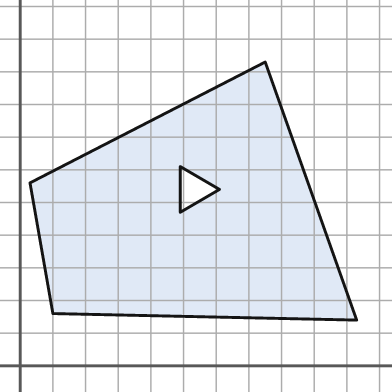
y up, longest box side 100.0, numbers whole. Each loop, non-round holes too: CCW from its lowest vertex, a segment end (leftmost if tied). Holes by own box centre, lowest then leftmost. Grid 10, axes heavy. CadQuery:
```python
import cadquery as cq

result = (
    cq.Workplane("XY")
    .moveTo(103.0, 14.0)
    .lineTo(75.0, 93.0)
    .lineTo(3.0, 56.0)
    .lineTo(10.0, 16.0)
    .close()
    .moveTo(49.0, 47.0)
    .lineTo(61.0, 54.0)
    .lineTo(49.0, 61.0)
    .close()
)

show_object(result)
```